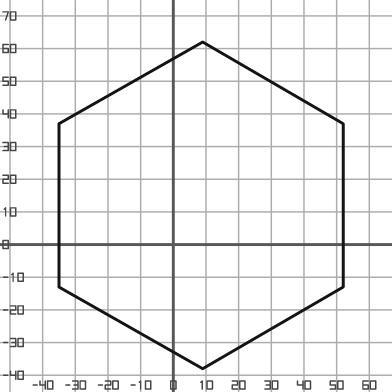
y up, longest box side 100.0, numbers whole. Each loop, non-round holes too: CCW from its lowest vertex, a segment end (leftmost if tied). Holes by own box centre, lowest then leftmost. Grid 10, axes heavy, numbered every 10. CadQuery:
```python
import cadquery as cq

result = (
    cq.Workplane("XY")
    .moveTo(9.0, -38.0)
    .lineTo(52.0, -13.0)
    .lineTo(52.0, 37.0)
    .lineTo(9.0, 62.0)
    .lineTo(-35.0, 37.0)
    .lineTo(-35.0, -13.0)
    .close()
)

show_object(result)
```